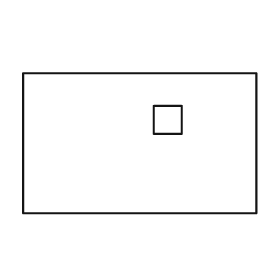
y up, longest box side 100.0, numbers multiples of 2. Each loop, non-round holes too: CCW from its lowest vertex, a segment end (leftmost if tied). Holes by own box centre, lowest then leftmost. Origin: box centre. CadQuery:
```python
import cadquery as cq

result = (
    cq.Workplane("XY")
    .moveTo(-50.0, -30.0)
    .lineTo(50.0, -30.0)
    .lineTo(50.0, 30.0)
    .lineTo(-50.0, 30.0)
    .close()
    .moveTo(6.0, 4.0)
    .lineTo(18.0, 4.0)
    .lineTo(18.0, 16.0)
    .lineTo(6.0, 16.0)
    .close()
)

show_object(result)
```